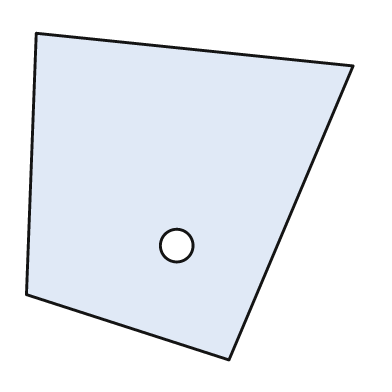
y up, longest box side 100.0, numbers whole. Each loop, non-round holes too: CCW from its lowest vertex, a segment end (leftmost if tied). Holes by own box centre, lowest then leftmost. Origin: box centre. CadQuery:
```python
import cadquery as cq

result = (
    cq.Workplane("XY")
    .moveTo(12.0, -50.0)
    .lineTo(50.0, 40.0)
    .lineTo(-47.0, 50.0)
    .lineTo(-50.0, -30.0)
    .close()
    .moveTo(-4.0, -15.0)
    .circle(5.0)
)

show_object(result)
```